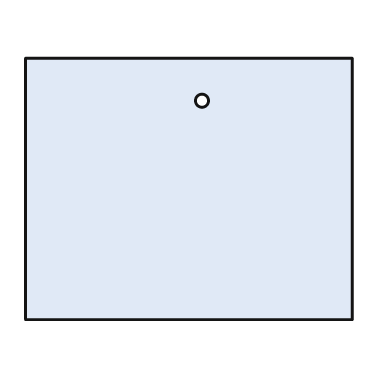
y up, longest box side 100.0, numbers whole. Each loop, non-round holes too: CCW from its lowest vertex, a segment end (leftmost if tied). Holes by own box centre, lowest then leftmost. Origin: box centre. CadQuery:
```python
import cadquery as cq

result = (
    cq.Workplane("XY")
    .moveTo(-50.0, -40.0)
    .lineTo(50.0, -40.0)
    .lineTo(50.0, 40.0)
    .lineTo(-50.0, 40.0)
    .close()
    .moveTo(4.0, 27.0)
    .circle(2.0)
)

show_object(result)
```